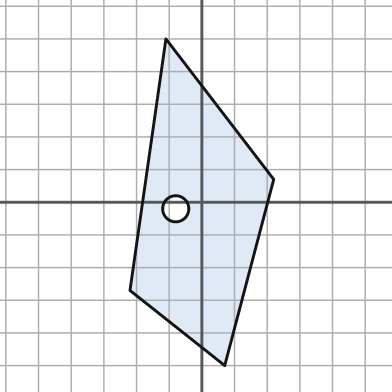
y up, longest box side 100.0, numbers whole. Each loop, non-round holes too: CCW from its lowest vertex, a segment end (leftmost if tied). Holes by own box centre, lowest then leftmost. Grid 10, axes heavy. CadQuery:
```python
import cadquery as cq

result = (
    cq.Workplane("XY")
    .moveTo(7.0, -50.0)
    .lineTo(22.0, 7.0)
    .lineTo(-11.0, 50.0)
    .lineTo(-22.0, -27.0)
    .close()
    .moveTo(-8.0, -2.0)
    .circle(4.0)
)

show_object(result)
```